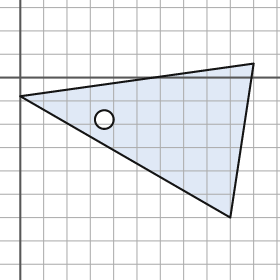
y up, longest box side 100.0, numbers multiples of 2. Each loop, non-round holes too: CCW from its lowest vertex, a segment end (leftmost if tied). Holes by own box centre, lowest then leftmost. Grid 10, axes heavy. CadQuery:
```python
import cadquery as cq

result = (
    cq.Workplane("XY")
    .moveTo(90.0, -60.0)
    .lineTo(100.0, 6.0)
    .lineTo(0.0, -8.0)
    .close()
    .moveTo(36.0, -18.0)
    .circle(4.0)
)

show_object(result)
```